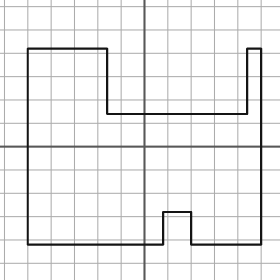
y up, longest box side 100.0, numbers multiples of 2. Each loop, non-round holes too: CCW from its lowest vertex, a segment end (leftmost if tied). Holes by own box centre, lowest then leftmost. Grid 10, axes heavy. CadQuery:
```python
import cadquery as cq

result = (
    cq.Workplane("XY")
    .moveTo(-50.0, -42.0)
    .lineTo(8.0, -42.0)
    .lineTo(8.0, -28.0)
    .lineTo(20.0, -28.0)
    .lineTo(20.0, -42.0)
    .lineTo(50.0, -42.0)
    .lineTo(50.0, 42.0)
    .lineTo(44.0, 42.0)
    .lineTo(44.0, 14.0)
    .lineTo(-16.0, 14.0)
    .lineTo(-16.0, 42.0)
    .lineTo(-50.0, 42.0)
    .close()
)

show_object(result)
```